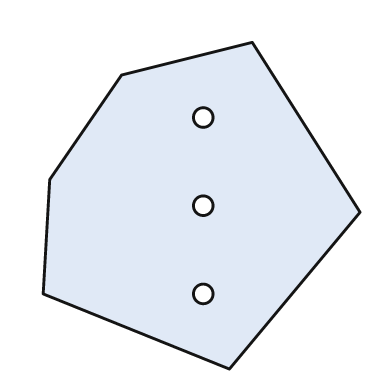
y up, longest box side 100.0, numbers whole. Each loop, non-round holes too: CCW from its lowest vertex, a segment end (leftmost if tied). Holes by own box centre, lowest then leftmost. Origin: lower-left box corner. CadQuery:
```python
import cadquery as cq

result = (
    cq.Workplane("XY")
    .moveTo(57.0, 0.0)
    .lineTo(97.0, 48.0)
    .lineTo(64.0, 100.0)
    .lineTo(24.0, 90.0)
    .lineTo(2.0, 58.0)
    .lineTo(0.0, 23.0)
    .close()
    .moveTo(49.0, 23.0)
    .circle(3.0)
    .moveTo(49.0, 50.0)
    .circle(3.0)
    .moveTo(49.0, 77.0)
    .circle(3.0)
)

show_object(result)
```